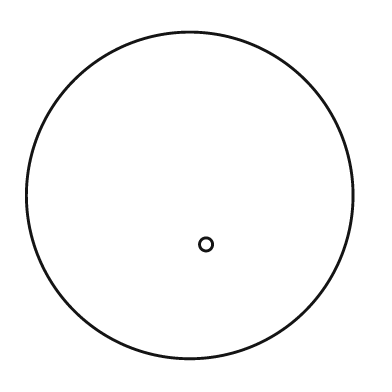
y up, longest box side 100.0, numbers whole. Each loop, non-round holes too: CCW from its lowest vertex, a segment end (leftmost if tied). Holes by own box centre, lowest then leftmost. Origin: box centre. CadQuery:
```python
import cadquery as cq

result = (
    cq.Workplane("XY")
    .moveTo(0.0, 0.0)
    .circle(50.0)
    .moveTo(5.0, -15.0)
    .circle(2.0)
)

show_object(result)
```